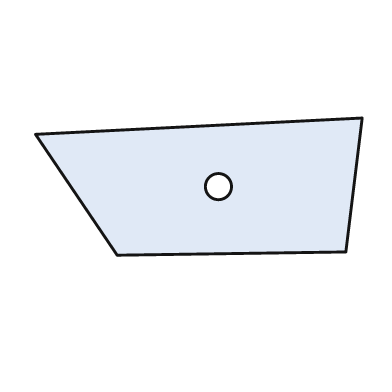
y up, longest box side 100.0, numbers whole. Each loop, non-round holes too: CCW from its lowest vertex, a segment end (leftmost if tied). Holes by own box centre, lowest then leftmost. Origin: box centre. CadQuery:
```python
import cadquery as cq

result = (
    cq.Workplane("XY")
    .moveTo(-25.0, -21.0)
    .lineTo(45.0, -20.0)
    .lineTo(50.0, 21.0)
    .lineTo(-50.0, 16.0)
    .close()
    .moveTo(6.0, 0.0)
    .circle(4.0)
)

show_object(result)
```